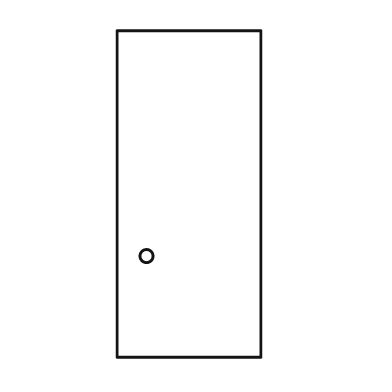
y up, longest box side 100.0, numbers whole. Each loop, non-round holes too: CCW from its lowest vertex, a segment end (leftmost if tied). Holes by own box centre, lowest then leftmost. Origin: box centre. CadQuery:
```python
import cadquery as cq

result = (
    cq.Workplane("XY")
    .moveTo(-22.0, -50.0)
    .lineTo(22.0, -50.0)
    .lineTo(22.0, 50.0)
    .lineTo(-22.0, 50.0)
    .close()
    .moveTo(-13.0, -19.0)
    .circle(2.0)
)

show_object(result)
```